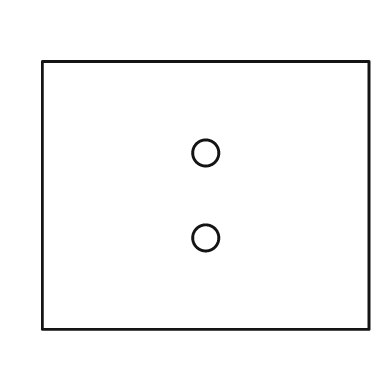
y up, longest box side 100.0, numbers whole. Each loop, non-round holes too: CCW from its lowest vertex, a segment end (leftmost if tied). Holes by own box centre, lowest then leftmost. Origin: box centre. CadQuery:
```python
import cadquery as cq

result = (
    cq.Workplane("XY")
    .moveTo(-50.0, -41.0)
    .lineTo(50.0, -41.0)
    .lineTo(50.0, 41.0)
    .lineTo(-50.0, 41.0)
    .close()
    .moveTo(0.0, -13.0)
    .circle(4.0)
    .moveTo(0.0, 13.0)
    .circle(4.0)
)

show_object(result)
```